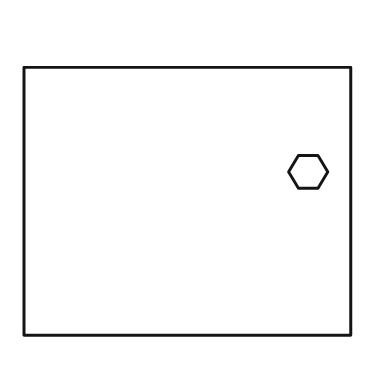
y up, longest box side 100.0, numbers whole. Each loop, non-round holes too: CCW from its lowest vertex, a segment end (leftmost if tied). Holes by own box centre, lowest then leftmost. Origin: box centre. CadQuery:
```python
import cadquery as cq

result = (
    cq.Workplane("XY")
    .moveTo(-50.0, -41.0)
    .lineTo(50.0, -41.0)
    .lineTo(50.0, 41.0)
    .lineTo(-50.0, 41.0)
    .close()
    .moveTo(34.0, 4.0)
    .lineTo(40.0, 4.0)
    .lineTo(43.0, 9.0)
    .lineTo(40.0, 14.0)
    .lineTo(34.0, 14.0)
    .lineTo(31.0, 9.0)
    .close()
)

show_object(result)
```